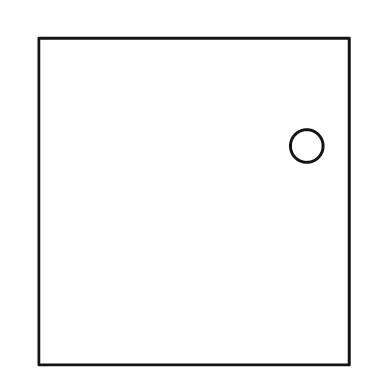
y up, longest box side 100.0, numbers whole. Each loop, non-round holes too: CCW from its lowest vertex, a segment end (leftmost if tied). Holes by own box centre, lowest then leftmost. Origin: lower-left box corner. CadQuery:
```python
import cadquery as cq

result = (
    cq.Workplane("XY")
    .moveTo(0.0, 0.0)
    .lineTo(95.0, 0.0)
    .lineTo(95.0, 100.0)
    .lineTo(0.0, 100.0)
    .close()
    .moveTo(82.0, 67.0)
    .circle(5.0)
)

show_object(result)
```